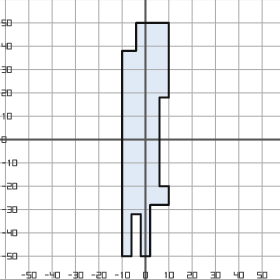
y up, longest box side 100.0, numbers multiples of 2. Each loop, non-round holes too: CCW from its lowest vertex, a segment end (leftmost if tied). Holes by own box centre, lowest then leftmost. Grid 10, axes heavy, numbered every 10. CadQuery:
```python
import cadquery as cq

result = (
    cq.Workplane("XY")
    .moveTo(-10.0, -50.0)
    .lineTo(-6.0, -50.0)
    .lineTo(-6.0, -32.0)
    .lineTo(-2.0, -32.0)
    .lineTo(-2.0, -50.0)
    .lineTo(2.0, -50.0)
    .lineTo(2.0, -28.0)
    .lineTo(10.0, -28.0)
    .lineTo(10.0, -20.0)
    .lineTo(6.0, -20.0)
    .lineTo(6.0, 18.0)
    .lineTo(10.0, 18.0)
    .lineTo(10.0, 50.0)
    .lineTo(-4.0, 50.0)
    .lineTo(-4.0, 38.0)
    .lineTo(-10.0, 38.0)
    .close()
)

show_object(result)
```